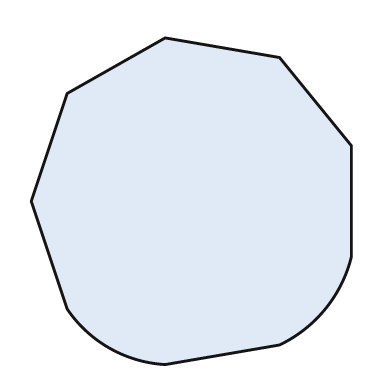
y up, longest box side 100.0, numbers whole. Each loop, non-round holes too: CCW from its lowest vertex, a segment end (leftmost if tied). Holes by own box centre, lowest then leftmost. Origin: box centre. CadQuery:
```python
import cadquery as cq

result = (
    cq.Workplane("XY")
    .moveTo(-8.0, -50.0)
    .lineTo(27.0, -44.0)
    .threePointArc((41.0, -33.0), (49.0, -17.0))
    .lineTo(49.0, 17.0)
    .lineTo(27.0, 44.0)
    .lineTo(-8.0, 50.0)
    .lineTo(-38.0, 33.0)
    .lineTo(-49.0, 0.0)
    .lineTo(-38.0, -33.0)
    .threePointArc((-25.0, -45.0), (-8.0, -50.0))
    .close()
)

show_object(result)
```